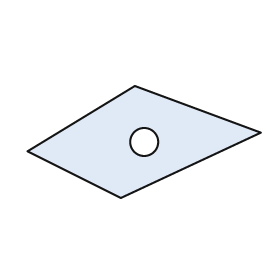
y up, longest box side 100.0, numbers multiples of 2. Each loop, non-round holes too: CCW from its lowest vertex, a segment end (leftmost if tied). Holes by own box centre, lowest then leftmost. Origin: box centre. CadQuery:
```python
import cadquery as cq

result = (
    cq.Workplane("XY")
    .moveTo(-10.0, -24.0)
    .lineTo(50.0, 4.0)
    .lineTo(-4.0, 24.0)
    .lineTo(-50.0, -4.0)
    .close()
    .moveTo(0.0, 0.0)
    .circle(6.0)
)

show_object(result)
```